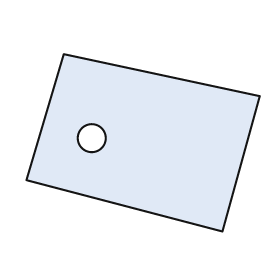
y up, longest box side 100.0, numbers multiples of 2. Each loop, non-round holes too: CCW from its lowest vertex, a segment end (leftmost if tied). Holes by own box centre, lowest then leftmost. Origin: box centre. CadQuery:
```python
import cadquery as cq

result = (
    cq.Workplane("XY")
    .moveTo(34.0, -38.0)
    .lineTo(50.0, 20.0)
    .lineTo(-34.0, 38.0)
    .lineTo(-50.0, -16.0)
    .close()
    .moveTo(-22.0, 2.0)
    .circle(6.0)
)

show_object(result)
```